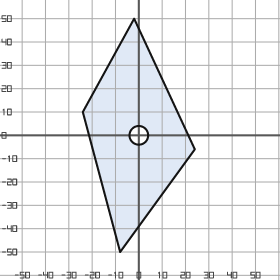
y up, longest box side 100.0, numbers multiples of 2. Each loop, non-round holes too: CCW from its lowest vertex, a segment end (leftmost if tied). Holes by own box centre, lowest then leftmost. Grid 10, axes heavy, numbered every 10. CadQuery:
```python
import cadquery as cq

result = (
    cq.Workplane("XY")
    .moveTo(-8.0, -50.0)
    .lineTo(24.0, -6.0)
    .lineTo(-2.0, 50.0)
    .lineTo(-24.0, 10.0)
    .close()
    .moveTo(0.0, 0.0)
    .circle(4.0)
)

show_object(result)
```